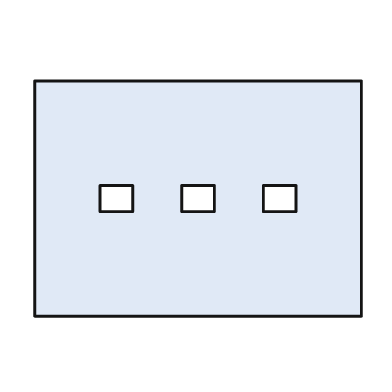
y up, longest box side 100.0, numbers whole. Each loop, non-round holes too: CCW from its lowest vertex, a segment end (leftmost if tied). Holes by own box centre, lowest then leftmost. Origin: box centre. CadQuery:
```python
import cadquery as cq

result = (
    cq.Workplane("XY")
    .moveTo(-50.0, -36.0)
    .lineTo(50.0, -36.0)
    .lineTo(50.0, 36.0)
    .lineTo(-50.0, 36.0)
    .close()
    .moveTo(-30.0, -4.0)
    .lineTo(-20.0, -4.0)
    .lineTo(-20.0, 4.0)
    .lineTo(-30.0, 4.0)
    .close()
    .moveTo(-5.0, -4.0)
    .lineTo(5.0, -4.0)
    .lineTo(5.0, 4.0)
    .lineTo(-5.0, 4.0)
    .close()
    .moveTo(20.0, -4.0)
    .lineTo(30.0, -4.0)
    .lineTo(30.0, 4.0)
    .lineTo(20.0, 4.0)
    .close()
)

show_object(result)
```